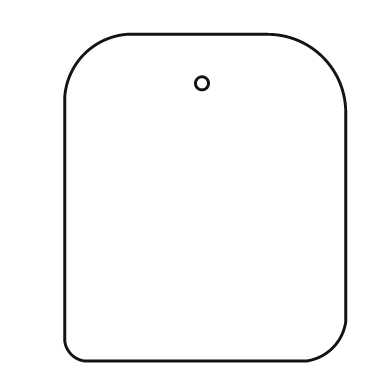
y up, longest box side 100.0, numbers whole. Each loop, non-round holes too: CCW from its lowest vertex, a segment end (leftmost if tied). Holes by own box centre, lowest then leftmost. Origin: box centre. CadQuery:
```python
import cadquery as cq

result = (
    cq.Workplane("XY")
    .moveTo(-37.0, -50.0)
    .lineTo(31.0, -50.0)
    .threePointArc((39.0, -46.0), (43.0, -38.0))
    .lineTo(43.0, 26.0)
    .threePointArc((36.0, 43.0), (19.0, 50.0))
    .lineTo(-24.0, 50.0)
    .threePointArc((-37.0, 44.0), (-43.0, 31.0))
    .lineTo(-43.0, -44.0)
    .threePointArc((-41.0, -48.0), (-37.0, -50.0))
    .close()
    .moveTo(-1.0, 35.0)
    .circle(2.0)
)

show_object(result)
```